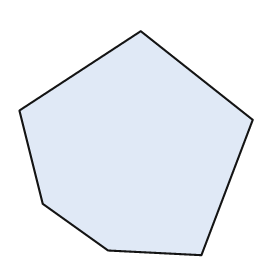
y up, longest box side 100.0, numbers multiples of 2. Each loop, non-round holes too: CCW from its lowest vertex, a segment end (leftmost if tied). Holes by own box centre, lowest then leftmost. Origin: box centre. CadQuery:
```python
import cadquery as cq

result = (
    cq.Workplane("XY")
    .moveTo(28.0, -48.0)
    .lineTo(50.0, 10.0)
    .lineTo(2.0, 48.0)
    .lineTo(-50.0, 14.0)
    .lineTo(-40.0, -26.0)
    .lineTo(-12.0, -46.0)
    .close()
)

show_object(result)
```